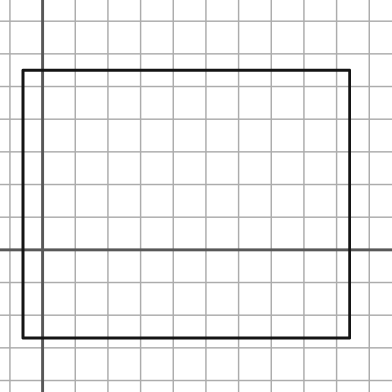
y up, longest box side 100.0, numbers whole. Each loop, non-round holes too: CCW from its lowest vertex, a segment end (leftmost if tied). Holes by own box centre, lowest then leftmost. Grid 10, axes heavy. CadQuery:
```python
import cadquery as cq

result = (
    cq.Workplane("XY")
    .moveTo(-6.0, -27.0)
    .lineTo(94.0, -27.0)
    .lineTo(94.0, 55.0)
    .lineTo(-6.0, 55.0)
    .close()
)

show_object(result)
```